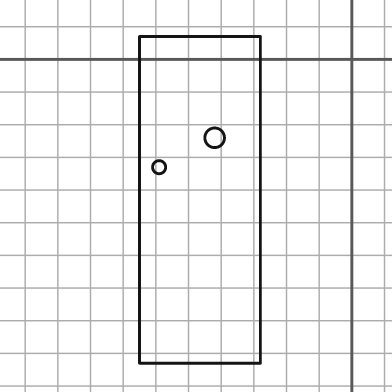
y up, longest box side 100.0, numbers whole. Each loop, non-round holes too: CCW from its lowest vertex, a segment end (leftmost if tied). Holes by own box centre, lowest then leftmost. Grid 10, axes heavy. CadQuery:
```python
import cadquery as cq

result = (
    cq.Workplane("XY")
    .moveTo(-65.0, -93.0)
    .lineTo(-28.0, -93.0)
    .lineTo(-28.0, 7.0)
    .lineTo(-65.0, 7.0)
    .close()
    .moveTo(-59.0, -33.0)
    .circle(2.0)
    .moveTo(-42.0, -24.0)
    .circle(3.0)
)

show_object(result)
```